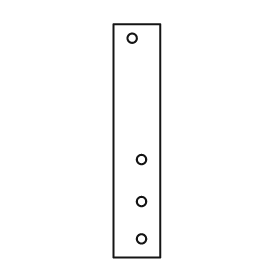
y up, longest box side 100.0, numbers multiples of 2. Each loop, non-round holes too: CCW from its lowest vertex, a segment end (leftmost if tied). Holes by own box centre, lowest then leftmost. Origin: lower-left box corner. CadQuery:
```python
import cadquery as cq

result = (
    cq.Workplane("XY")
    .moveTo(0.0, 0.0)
    .lineTo(20.0, 0.0)
    .lineTo(20.0, 100.0)
    .lineTo(0.0, 100.0)
    .close()
    .moveTo(12.0, 8.0)
    .circle(2.0)
    .moveTo(12.0, 24.0)
    .circle(2.0)
    .moveTo(12.0, 42.0)
    .circle(2.0)
    .moveTo(8.0, 94.0)
    .circle(2.0)
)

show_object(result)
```